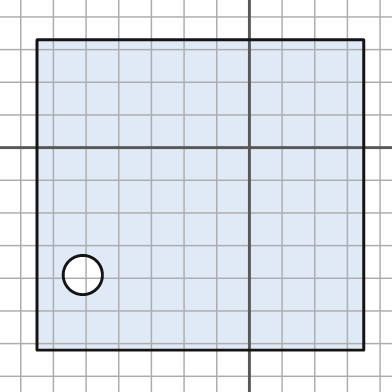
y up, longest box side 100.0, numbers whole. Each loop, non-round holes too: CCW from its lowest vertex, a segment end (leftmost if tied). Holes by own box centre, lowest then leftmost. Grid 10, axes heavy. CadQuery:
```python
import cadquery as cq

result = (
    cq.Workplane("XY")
    .moveTo(-65.0, -62.0)
    .lineTo(35.0, -62.0)
    .lineTo(35.0, 33.0)
    .lineTo(-65.0, 33.0)
    .close()
    .moveTo(-51.0, -39.0)
    .circle(6.0)
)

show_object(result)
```